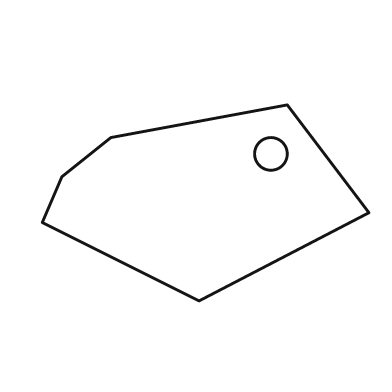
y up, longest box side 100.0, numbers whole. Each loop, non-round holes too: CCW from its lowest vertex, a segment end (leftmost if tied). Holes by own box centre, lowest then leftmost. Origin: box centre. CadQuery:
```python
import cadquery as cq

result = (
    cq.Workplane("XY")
    .moveTo(-2.0, -30.0)
    .lineTo(50.0, -3.0)
    .lineTo(25.0, 30.0)
    .lineTo(-29.0, 20.0)
    .lineTo(-44.0, 8.0)
    .lineTo(-50.0, -6.0)
    .close()
    .moveTo(20.0, 15.0)
    .circle(5.0)
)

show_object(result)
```